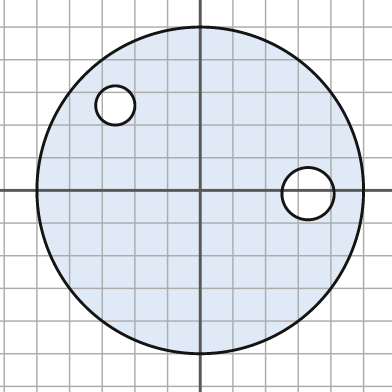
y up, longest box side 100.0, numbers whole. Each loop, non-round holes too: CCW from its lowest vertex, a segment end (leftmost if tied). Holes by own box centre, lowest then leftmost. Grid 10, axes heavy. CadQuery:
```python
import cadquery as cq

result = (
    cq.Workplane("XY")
    .moveTo(0.0, 0.0)
    .circle(50.0)
    .moveTo(33.0, -1.0)
    .circle(8.0)
    .moveTo(-26.0, 26.0)
    .circle(6.0)
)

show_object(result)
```